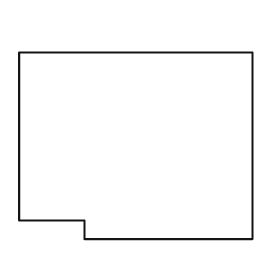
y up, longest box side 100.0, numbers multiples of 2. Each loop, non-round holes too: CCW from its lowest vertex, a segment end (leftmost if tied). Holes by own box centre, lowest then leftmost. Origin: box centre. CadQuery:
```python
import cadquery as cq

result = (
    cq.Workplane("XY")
    .moveTo(-22.0, -40.0)
    .lineTo(50.0, -40.0)
    .lineTo(50.0, 40.0)
    .lineTo(-50.0, 40.0)
    .lineTo(-50.0, -32.0)
    .lineTo(-22.0, -32.0)
    .close()
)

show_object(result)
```